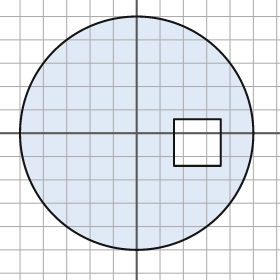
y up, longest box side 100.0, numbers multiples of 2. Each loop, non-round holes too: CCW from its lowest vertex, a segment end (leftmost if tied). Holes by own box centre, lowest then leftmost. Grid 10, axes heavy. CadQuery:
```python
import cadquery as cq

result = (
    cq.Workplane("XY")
    .moveTo(0.0, 0.0)
    .circle(50.0)
    .moveTo(16.0, -14.0)
    .lineTo(36.0, -14.0)
    .lineTo(36.0, 6.0)
    .lineTo(16.0, 6.0)
    .close()
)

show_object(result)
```